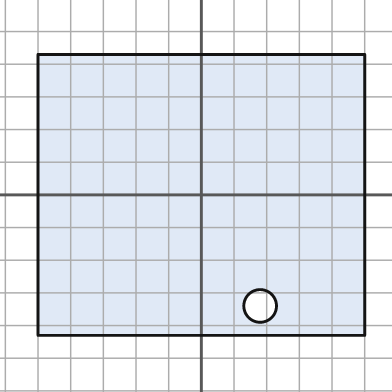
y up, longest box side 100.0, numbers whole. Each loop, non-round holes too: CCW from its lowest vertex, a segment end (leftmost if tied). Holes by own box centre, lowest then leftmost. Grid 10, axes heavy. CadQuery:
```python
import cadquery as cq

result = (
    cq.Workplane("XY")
    .moveTo(-50.0, -43.0)
    .lineTo(50.0, -43.0)
    .lineTo(50.0, 43.0)
    .lineTo(-50.0, 43.0)
    .close()
    .moveTo(18.0, -34.0)
    .circle(5.0)
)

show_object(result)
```